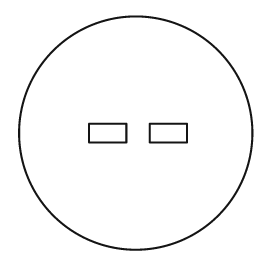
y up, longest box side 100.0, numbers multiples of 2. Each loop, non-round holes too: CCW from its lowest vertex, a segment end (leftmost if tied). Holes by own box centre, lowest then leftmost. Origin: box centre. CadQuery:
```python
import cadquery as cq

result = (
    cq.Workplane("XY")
    .moveTo(0.0, 0.0)
    .circle(50.0)
    .moveTo(-20.0, -4.0)
    .lineTo(-4.0, -4.0)
    .lineTo(-4.0, 4.0)
    .lineTo(-20.0, 4.0)
    .close()
    .moveTo(6.0, -4.0)
    .lineTo(22.0, -4.0)
    .lineTo(22.0, 4.0)
    .lineTo(6.0, 4.0)
    .close()
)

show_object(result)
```